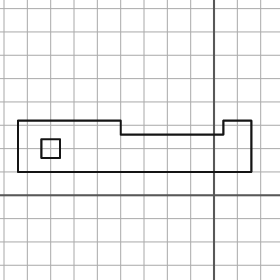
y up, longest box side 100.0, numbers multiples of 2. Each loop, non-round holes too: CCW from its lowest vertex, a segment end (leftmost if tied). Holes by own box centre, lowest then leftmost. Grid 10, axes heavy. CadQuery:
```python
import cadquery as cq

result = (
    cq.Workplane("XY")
    .moveTo(-84.0, 10.0)
    .lineTo(16.0, 10.0)
    .lineTo(16.0, 32.0)
    .lineTo(4.0, 32.0)
    .lineTo(4.0, 26.0)
    .lineTo(-40.0, 26.0)
    .lineTo(-40.0, 32.0)
    .lineTo(-84.0, 32.0)
    .close()
    .moveTo(-74.0, 16.0)
    .lineTo(-66.0, 16.0)
    .lineTo(-66.0, 24.0)
    .lineTo(-74.0, 24.0)
    .close()
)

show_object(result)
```